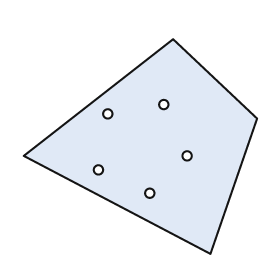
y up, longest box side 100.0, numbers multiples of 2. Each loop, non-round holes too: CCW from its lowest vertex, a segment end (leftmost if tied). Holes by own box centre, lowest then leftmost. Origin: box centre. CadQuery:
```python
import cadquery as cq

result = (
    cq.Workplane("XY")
    .moveTo(30.0, -46.0)
    .lineTo(50.0, 12.0)
    .lineTo(14.0, 46.0)
    .lineTo(-50.0, -4.0)
    .close()
    .moveTo(4.0, -20.0)
    .circle(2.0)
    .moveTo(-18.0, -10.0)
    .circle(2.0)
    .moveTo(20.0, -4.0)
    .circle(2.0)
    .moveTo(-14.0, 14.0)
    .circle(2.0)
    .moveTo(10.0, 18.0)
    .circle(2.0)
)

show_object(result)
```